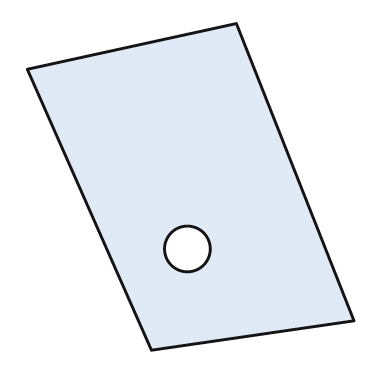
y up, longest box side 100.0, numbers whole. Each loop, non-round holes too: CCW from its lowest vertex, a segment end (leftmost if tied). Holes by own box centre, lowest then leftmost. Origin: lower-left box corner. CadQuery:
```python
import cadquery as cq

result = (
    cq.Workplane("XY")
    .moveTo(38.0, 0.0)
    .lineTo(100.0, 9.0)
    .lineTo(64.0, 100.0)
    .lineTo(0.0, 86.0)
    .close()
    .moveTo(49.0, 31.0)
    .circle(7.0)
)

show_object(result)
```